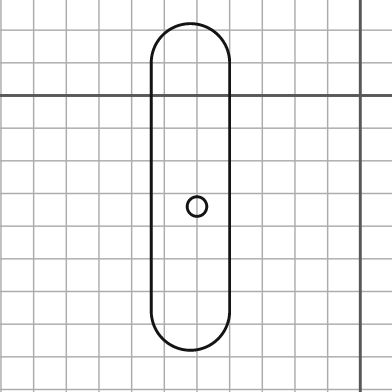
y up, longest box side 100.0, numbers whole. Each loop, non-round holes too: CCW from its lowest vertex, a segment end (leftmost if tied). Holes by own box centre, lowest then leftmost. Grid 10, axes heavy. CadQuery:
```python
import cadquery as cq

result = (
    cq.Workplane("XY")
    .moveTo(-64.0, -66.0)
    .threePointArc((-52.0, -78.0), (-40.0, -66.0))
    .lineTo(-40.0, 10.0)
    .threePointArc((-52.0, 22.0), (-64.0, 10.0))
    .close()
    .moveTo(-50.0, -34.0)
    .circle(3.0)
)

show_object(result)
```